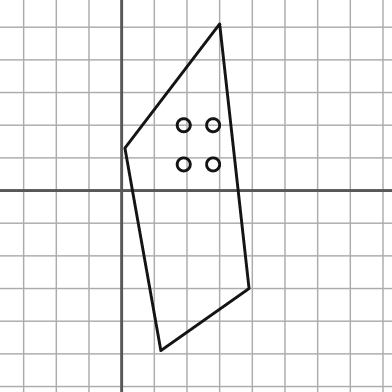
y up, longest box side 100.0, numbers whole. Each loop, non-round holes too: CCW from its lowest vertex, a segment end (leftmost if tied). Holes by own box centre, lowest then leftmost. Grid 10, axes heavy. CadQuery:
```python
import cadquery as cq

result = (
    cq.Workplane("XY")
    .moveTo(12.0, -49.0)
    .lineTo(39.0, -30.0)
    .lineTo(30.0, 51.0)
    .lineTo(1.0, 13.0)
    .close()
    .moveTo(19.0, 8.0)
    .circle(2.0)
    .moveTo(28.0, 8.0)
    .circle(2.0)
    .moveTo(19.0, 20.0)
    .circle(2.0)
    .moveTo(28.0, 20.0)
    .circle(2.0)
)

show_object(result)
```